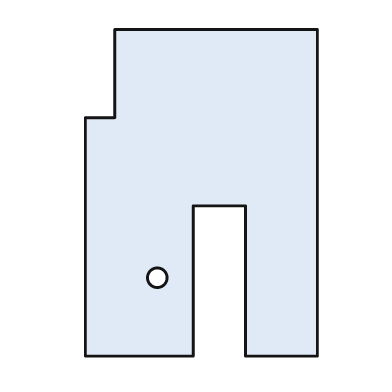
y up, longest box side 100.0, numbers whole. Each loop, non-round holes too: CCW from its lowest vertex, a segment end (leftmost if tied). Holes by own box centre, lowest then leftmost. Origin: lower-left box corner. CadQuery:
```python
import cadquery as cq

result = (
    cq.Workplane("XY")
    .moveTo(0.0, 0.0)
    .lineTo(33.0, 0.0)
    .lineTo(33.0, 46.0)
    .lineTo(49.0, 46.0)
    .lineTo(49.0, 0.0)
    .lineTo(71.0, 0.0)
    .lineTo(71.0, 100.0)
    .lineTo(9.0, 100.0)
    .lineTo(9.0, 73.0)
    .lineTo(0.0, 73.0)
    .close()
    .moveTo(22.0, 24.0)
    .circle(3.0)
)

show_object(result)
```